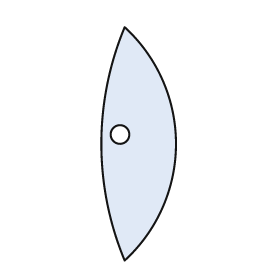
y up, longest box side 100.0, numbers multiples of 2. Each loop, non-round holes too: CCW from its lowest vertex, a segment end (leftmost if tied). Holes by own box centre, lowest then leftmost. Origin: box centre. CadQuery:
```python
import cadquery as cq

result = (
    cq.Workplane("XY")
    .moveTo(-6.0, -50.0)
    .threePointArc((16.0, 0.0), (-6.0, 50.0))
    .threePointArc((-16.0, 0.0), (-6.0, -50.0))
    .close()
    .moveTo(-8.0, 4.0)
    .circle(4.0)
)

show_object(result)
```